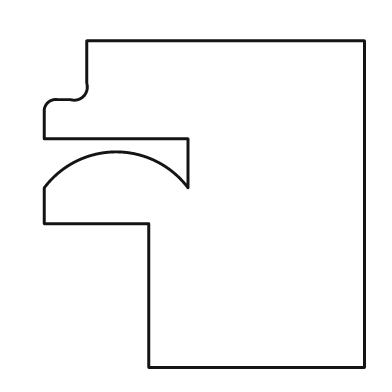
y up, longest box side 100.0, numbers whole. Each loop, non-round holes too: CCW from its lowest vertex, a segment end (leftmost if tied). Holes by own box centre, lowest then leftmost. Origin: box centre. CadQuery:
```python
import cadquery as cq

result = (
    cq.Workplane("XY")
    .moveTo(-17.0, -50.0)
    .lineTo(49.0, -50.0)
    .lineTo(49.0, 50.0)
    .lineTo(-36.0, 50.0)
    .lineTo(-36.0, 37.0)
    .threePointArc((-37.0, 33.0), (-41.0, 32.0))
    .lineTo(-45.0, 32.0)
    .threePointArc((-48.0, 31.0), (-49.0, 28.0))
    .lineTo(-49.0, 20.0)
    .lineTo(-5.0, 20.0)
    .lineTo(-5.0, 5.0)
    .threePointArc((-27.0, 16.0), (-49.0, 5.0))
    .lineTo(-49.0, -6.0)
    .lineTo(-17.0, -6.0)
    .close()
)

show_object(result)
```